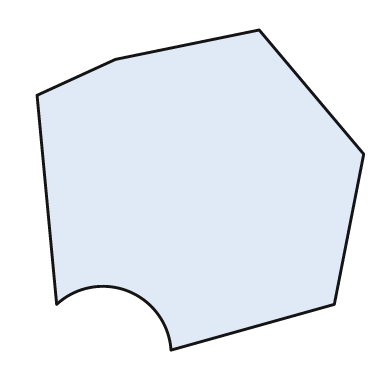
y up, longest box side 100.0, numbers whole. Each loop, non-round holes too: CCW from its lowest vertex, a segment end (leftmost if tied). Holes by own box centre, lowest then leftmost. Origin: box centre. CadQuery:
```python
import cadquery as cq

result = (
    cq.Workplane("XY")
    .moveTo(-9.0, -49.0)
    .lineTo(41.0, -35.0)
    .lineTo(50.0, 11.0)
    .lineTo(18.0, 49.0)
    .lineTo(-26.0, 40.0)
    .lineTo(-50.0, 29.0)
    .lineTo(-44.0, -35.0)
    .threePointArc((-22.0, -31.0), (-9.0, -49.0))
    .close()
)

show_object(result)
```